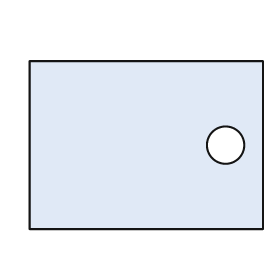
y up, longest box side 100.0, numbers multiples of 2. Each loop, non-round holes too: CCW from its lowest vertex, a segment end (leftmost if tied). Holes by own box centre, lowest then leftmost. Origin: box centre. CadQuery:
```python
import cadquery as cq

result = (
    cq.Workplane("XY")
    .moveTo(-50.0, -36.0)
    .lineTo(50.0, -36.0)
    .lineTo(50.0, 36.0)
    .lineTo(-50.0, 36.0)
    .close()
    .moveTo(34.0, 0.0)
    .circle(8.0)
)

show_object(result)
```